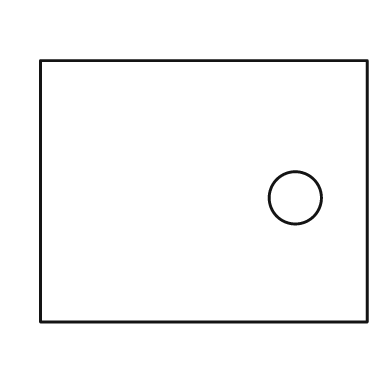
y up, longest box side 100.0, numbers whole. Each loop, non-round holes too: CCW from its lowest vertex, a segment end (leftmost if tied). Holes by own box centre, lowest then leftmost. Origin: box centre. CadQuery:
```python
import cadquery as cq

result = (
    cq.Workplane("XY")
    .moveTo(-50.0, -40.0)
    .lineTo(50.0, -40.0)
    .lineTo(50.0, 40.0)
    .lineTo(-50.0, 40.0)
    .close()
    .moveTo(28.0, -2.0)
    .circle(8.0)
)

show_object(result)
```